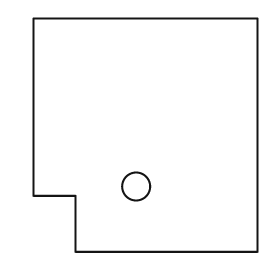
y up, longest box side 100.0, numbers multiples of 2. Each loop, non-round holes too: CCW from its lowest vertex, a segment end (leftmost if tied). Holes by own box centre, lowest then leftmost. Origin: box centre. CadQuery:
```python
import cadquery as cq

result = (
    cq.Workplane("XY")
    .moveTo(-30.0, -50.0)
    .lineTo(48.0, -50.0)
    .lineTo(48.0, 50.0)
    .lineTo(-48.0, 50.0)
    .lineTo(-48.0, -26.0)
    .lineTo(-30.0, -26.0)
    .close()
    .moveTo(-4.0, -22.0)
    .circle(6.0)
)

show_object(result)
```